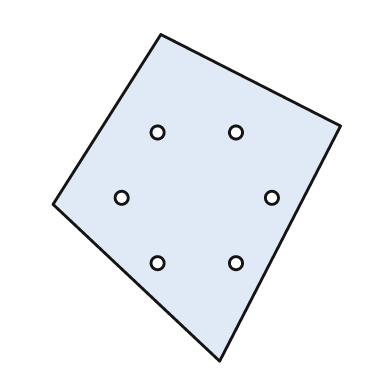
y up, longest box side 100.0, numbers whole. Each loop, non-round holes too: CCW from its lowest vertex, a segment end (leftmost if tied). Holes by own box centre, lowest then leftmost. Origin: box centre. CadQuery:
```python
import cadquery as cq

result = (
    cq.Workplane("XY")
    .moveTo(7.0, -50.0)
    .lineTo(44.0, 22.0)
    .lineTo(-11.0, 50.0)
    .lineTo(-44.0, -2.0)
    .close()
    .moveTo(-12.0, -20.0)
    .circle(2.0)
    .moveTo(12.0, -20.0)
    .circle(2.0)
    .moveTo(-23.0, 0.0)
    .circle(2.0)
    .moveTo(23.0, 0.0)
    .circle(2.0)
    .moveTo(-12.0, 20.0)
    .circle(2.0)
    .moveTo(12.0, 20.0)
    .circle(2.0)
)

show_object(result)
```